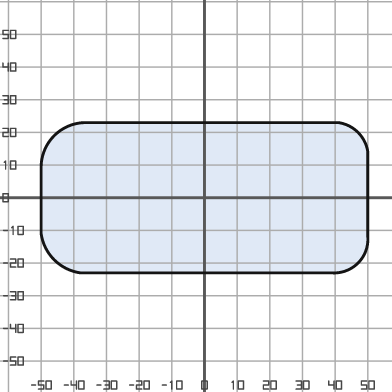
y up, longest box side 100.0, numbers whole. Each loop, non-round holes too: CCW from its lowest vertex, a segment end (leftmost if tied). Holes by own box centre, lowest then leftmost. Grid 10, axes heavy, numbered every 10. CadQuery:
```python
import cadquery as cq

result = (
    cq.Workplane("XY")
    .moveTo(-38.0, -23.0)
    .lineTo(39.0, -23.0)
    .threePointArc((47.0, -20.0), (50.0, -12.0))
    .lineTo(50.0, 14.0)
    .threePointArc((47.0, 20.0), (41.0, 23.0))
    .lineTo(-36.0, 23.0)
    .threePointArc((-46.0, 19.0), (-50.0, 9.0))
    .lineTo(-50.0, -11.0)
    .threePointArc((-46.0, -19.0), (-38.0, -23.0))
    .close()
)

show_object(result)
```